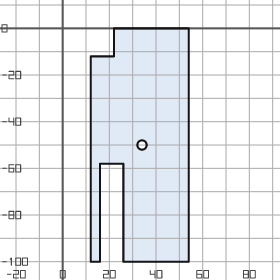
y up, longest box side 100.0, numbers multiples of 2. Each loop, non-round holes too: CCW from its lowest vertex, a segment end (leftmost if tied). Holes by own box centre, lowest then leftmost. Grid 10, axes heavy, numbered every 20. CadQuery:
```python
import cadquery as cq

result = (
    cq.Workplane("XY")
    .moveTo(12.0, -100.0)
    .lineTo(16.0, -100.0)
    .lineTo(16.0, -58.0)
    .lineTo(26.0, -58.0)
    .lineTo(26.0, -100.0)
    .lineTo(54.0, -100.0)
    .lineTo(54.0, 0.0)
    .lineTo(22.0, 0.0)
    .lineTo(22.0, -12.0)
    .lineTo(12.0, -12.0)
    .close()
    .moveTo(34.0, -50.0)
    .circle(2.0)
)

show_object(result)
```